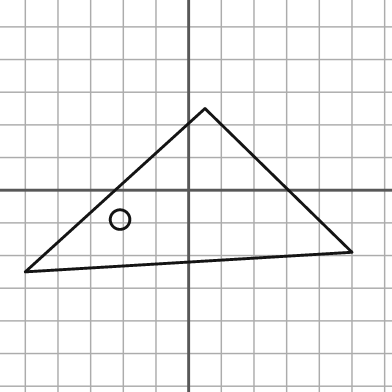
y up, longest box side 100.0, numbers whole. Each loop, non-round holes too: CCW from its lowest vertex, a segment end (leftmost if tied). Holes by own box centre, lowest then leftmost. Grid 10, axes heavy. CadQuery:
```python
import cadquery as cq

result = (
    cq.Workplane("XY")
    .moveTo(-50.0, -25.0)
    .lineTo(50.0, -19.0)
    .lineTo(5.0, 25.0)
    .close()
    .moveTo(-21.0, -9.0)
    .circle(3.0)
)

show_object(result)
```